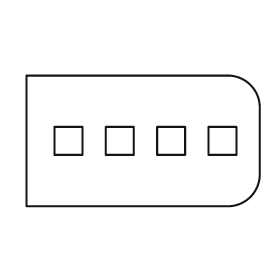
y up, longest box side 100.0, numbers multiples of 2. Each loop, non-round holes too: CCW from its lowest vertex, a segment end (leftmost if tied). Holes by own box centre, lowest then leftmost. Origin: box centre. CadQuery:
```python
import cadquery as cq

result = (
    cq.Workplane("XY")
    .moveTo(-50.0, -28.0)
    .lineTo(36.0, -28.0)
    .threePointArc((46.0, -24.0), (50.0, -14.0))
    .lineTo(50.0, 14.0)
    .threePointArc((46.0, 24.0), (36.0, 28.0))
    .lineTo(-50.0, 28.0)
    .close()
    .moveTo(-38.0, -6.0)
    .lineTo(-26.0, -6.0)
    .lineTo(-26.0, 6.0)
    .lineTo(-38.0, 6.0)
    .close()
    .moveTo(-16.0, -6.0)
    .lineTo(-4.0, -6.0)
    .lineTo(-4.0, 6.0)
    .lineTo(-16.0, 6.0)
    .close()
    .moveTo(6.0, -6.0)
    .lineTo(18.0, -6.0)
    .lineTo(18.0, 6.0)
    .lineTo(6.0, 6.0)
    .close()
    .moveTo(28.0, -6.0)
    .lineTo(40.0, -6.0)
    .lineTo(40.0, 6.0)
    .lineTo(28.0, 6.0)
    .close()
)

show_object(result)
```